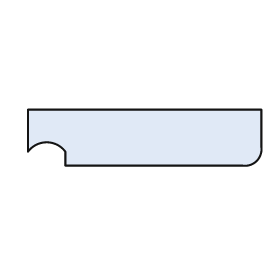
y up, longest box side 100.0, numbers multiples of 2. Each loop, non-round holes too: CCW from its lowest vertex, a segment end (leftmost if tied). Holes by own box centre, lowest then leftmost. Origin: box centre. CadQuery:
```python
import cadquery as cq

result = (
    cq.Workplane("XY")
    .moveTo(-34.0, -12.0)
    .lineTo(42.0, -12.0)
    .threePointArc((48.0, -10.0), (50.0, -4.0))
    .lineTo(50.0, 12.0)
    .lineTo(-50.0, 12.0)
    .lineTo(-50.0, -6.0)
    .threePointArc((-42.0, -2.0), (-34.0, -6.0))
    .close()
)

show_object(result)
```